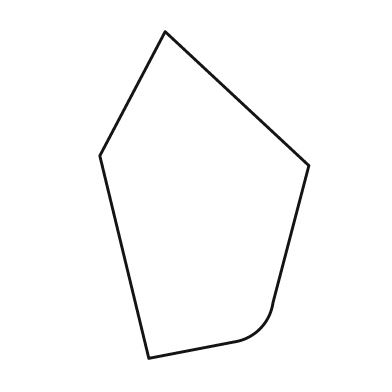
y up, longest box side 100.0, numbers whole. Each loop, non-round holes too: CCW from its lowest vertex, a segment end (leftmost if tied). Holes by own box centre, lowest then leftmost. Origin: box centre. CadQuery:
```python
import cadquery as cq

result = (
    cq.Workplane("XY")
    .moveTo(-17.0, -50.0)
    .lineTo(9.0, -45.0)
    .threePointArc((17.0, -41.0), (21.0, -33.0))
    .lineTo(32.0, 9.0)
    .lineTo(-12.0, 50.0)
    .lineTo(-32.0, 12.0)
    .close()
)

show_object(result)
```